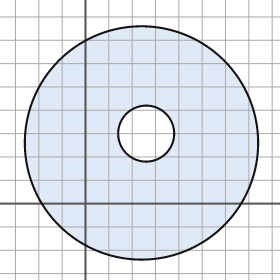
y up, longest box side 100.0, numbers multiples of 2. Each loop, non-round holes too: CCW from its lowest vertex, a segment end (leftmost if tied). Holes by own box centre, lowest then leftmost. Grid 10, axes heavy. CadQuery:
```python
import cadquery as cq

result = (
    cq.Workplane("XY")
    .moveTo(24.0, 26.0)
    .circle(50.0)
    .moveTo(26.0, 30.0)
    .circle(12.0)
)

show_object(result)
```